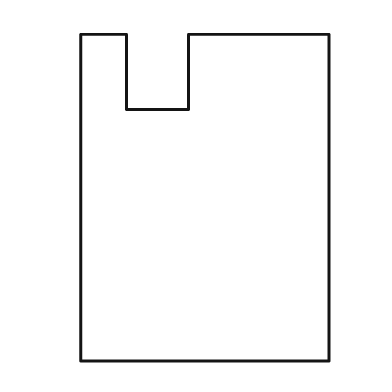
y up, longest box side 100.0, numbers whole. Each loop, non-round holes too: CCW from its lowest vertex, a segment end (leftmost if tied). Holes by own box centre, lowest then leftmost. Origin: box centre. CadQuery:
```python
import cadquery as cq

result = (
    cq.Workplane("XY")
    .moveTo(-38.0, -50.0)
    .lineTo(38.0, -50.0)
    .lineTo(38.0, 50.0)
    .lineTo(-5.0, 50.0)
    .lineTo(-5.0, 27.0)
    .lineTo(-24.0, 27.0)
    .lineTo(-24.0, 50.0)
    .lineTo(-38.0, 50.0)
    .close()
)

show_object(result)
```